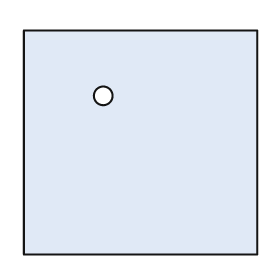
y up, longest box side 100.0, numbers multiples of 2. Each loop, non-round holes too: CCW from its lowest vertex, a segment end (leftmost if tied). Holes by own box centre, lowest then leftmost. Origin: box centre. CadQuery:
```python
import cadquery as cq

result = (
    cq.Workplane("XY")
    .moveTo(-50.0, -48.0)
    .lineTo(50.0, -48.0)
    .lineTo(50.0, 48.0)
    .lineTo(-50.0, 48.0)
    .close()
    .moveTo(-16.0, 20.0)
    .circle(4.0)
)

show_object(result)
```